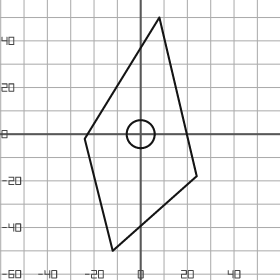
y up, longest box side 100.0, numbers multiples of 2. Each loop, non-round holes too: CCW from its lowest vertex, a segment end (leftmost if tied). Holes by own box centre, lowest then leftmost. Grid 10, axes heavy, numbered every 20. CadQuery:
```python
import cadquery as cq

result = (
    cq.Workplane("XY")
    .moveTo(-12.0, -50.0)
    .lineTo(24.0, -18.0)
    .lineTo(8.0, 50.0)
    .lineTo(-24.0, -2.0)
    .close()
    .moveTo(0.0, 0.0)
    .circle(6.0)
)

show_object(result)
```